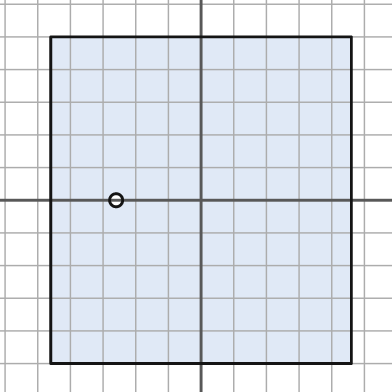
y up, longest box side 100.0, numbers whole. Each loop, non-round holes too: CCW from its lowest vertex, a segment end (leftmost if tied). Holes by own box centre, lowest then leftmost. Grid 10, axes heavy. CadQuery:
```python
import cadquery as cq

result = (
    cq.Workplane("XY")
    .moveTo(-46.0, -50.0)
    .lineTo(46.0, -50.0)
    .lineTo(46.0, 50.0)
    .lineTo(-46.0, 50.0)
    .close()
    .moveTo(-26.0, 0.0)
    .circle(2.0)
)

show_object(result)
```